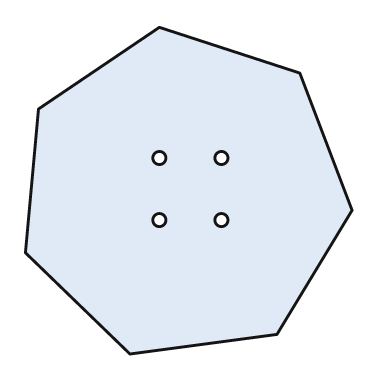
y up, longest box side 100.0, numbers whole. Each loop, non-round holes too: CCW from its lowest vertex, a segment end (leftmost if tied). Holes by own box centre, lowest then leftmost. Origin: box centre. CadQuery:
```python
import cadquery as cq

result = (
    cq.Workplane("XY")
    .moveTo(-18.0, -50.0)
    .lineTo(27.0, -44.0)
    .lineTo(50.0, -6.0)
    .lineTo(34.0, 36.0)
    .lineTo(-9.0, 50.0)
    .lineTo(-46.0, 25.0)
    .lineTo(-50.0, -19.0)
    .close()
    .moveTo(-9.0, -9.0)
    .circle(2.0)
    .moveTo(10.0, -9.0)
    .circle(2.0)
    .moveTo(-9.0, 10.0)
    .circle(2.0)
    .moveTo(10.0, 10.0)
    .circle(2.0)
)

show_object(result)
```